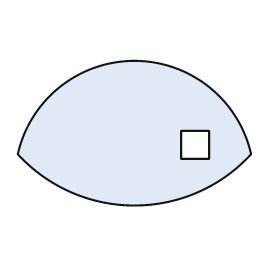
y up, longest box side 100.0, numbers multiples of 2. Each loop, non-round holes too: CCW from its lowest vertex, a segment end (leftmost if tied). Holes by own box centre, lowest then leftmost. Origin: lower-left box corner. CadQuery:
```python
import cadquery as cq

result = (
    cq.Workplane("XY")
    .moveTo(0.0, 22.0)
    .threePointArc((50.0, 0.0), (100.0, 22.0))
    .threePointArc((50.0, 62.0), (0.0, 22.0))
    .close()
    .moveTo(70.0, 20.0)
    .lineTo(82.0, 20.0)
    .lineTo(82.0, 32.0)
    .lineTo(70.0, 32.0)
    .close()
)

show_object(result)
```